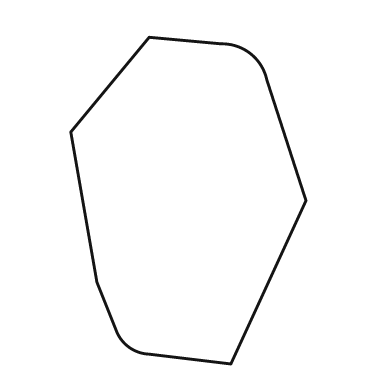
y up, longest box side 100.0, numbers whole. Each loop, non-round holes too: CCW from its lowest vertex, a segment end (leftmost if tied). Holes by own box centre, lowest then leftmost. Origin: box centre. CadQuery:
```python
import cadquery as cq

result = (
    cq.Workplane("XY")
    .moveTo(13.0, -50.0)
    .lineTo(36.0, 0.0)
    .lineTo(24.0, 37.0)
    .threePointArc((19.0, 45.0), (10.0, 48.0))
    .lineTo(-12.0, 50.0)
    .lineTo(-36.0, 21.0)
    .lineTo(-28.0, -25.0)
    .lineTo(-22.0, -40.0)
    .threePointArc((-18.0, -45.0), (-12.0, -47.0))
    .close()
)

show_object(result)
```